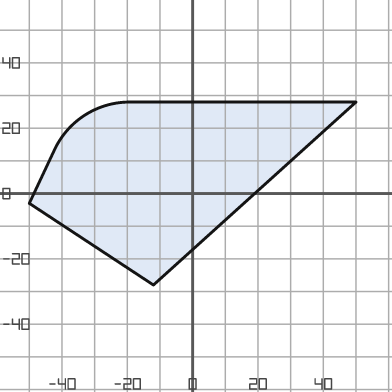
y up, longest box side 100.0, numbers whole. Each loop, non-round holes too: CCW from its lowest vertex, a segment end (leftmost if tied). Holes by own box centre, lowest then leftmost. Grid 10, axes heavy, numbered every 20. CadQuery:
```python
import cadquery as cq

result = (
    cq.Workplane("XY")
    .moveTo(-12.0, -28.0)
    .lineTo(50.0, 28.0)
    .lineTo(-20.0, 28.0)
    .threePointArc((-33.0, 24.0), (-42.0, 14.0))
    .lineTo(-50.0, -3.0)
    .close()
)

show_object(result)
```